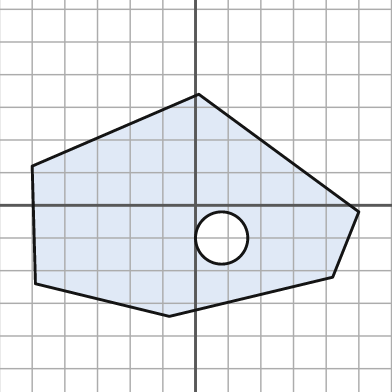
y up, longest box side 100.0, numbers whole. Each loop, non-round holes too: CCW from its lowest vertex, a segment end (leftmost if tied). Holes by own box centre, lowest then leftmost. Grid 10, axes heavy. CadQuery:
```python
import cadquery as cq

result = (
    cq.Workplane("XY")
    .moveTo(-8.0, -34.0)
    .lineTo(42.0, -22.0)
    .lineTo(50.0, -2.0)
    .lineTo(1.0, 34.0)
    .lineTo(-50.0, 12.0)
    .lineTo(-49.0, -24.0)
    .close()
    .moveTo(8.0, -10.0)
    .circle(8.0)
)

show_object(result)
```